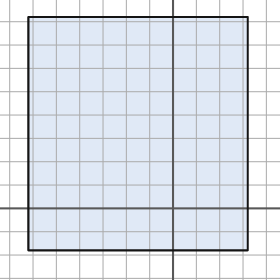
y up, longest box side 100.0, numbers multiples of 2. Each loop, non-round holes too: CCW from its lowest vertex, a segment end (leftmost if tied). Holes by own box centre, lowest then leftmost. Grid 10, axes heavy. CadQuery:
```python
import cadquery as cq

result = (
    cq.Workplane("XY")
    .moveTo(-62.0, -18.0)
    .lineTo(32.0, -18.0)
    .lineTo(32.0, 82.0)
    .lineTo(-62.0, 82.0)
    .close()
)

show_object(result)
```